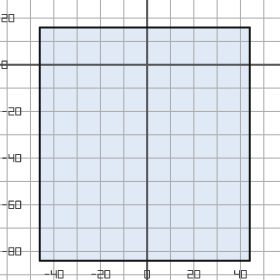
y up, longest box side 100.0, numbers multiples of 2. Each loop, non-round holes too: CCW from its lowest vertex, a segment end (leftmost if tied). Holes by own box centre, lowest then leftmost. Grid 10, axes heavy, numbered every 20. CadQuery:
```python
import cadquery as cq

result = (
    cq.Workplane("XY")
    .moveTo(-46.0, -84.0)
    .lineTo(44.0, -84.0)
    .lineTo(44.0, 16.0)
    .lineTo(-46.0, 16.0)
    .close()
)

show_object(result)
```